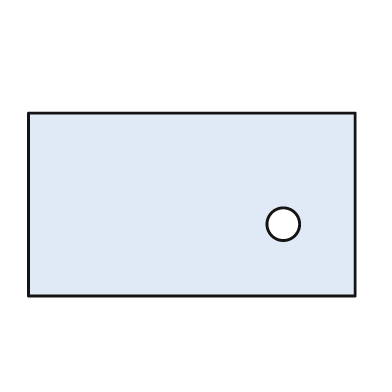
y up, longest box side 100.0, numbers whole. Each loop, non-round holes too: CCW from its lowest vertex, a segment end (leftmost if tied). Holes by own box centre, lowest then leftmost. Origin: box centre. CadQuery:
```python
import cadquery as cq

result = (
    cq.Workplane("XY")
    .moveTo(-50.0, -28.0)
    .lineTo(50.0, -28.0)
    .lineTo(50.0, 28.0)
    .lineTo(-50.0, 28.0)
    .close()
    .moveTo(28.0, -6.0)
    .circle(5.0)
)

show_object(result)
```